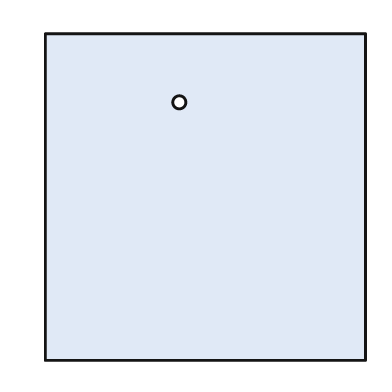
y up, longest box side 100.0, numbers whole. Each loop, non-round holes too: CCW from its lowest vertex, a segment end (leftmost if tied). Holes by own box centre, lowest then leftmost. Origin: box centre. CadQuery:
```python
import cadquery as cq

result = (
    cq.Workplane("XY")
    .moveTo(-49.0, -50.0)
    .lineTo(49.0, -50.0)
    .lineTo(49.0, 50.0)
    .lineTo(-49.0, 50.0)
    .close()
    .moveTo(-8.0, 29.0)
    .circle(2.0)
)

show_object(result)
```